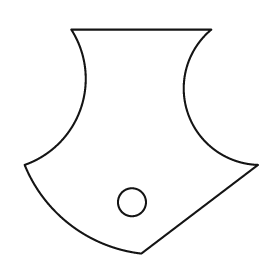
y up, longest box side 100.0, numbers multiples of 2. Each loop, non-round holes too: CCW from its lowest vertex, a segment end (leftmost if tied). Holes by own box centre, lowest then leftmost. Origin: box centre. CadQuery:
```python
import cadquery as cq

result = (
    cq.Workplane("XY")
    .moveTo(0.0, -48.0)
    .lineTo(50.0, -10.0)
    .threePointArc((20.0, 12.0), (30.0, 48.0))
    .lineTo(-30.0, 48.0)
    .threePointArc((-26.0, 14.0), (-50.0, -10.0))
    .threePointArc((-30.0, -36.0), (0.0, -48.0))
    .close()
    .moveTo(-4.0, -26.0)
    .circle(6.0)
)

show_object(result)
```